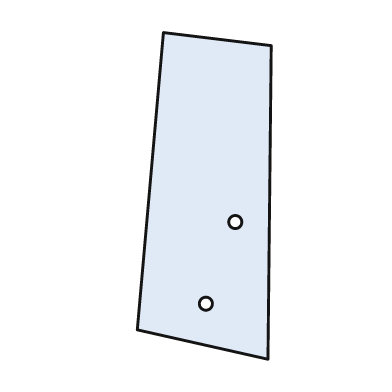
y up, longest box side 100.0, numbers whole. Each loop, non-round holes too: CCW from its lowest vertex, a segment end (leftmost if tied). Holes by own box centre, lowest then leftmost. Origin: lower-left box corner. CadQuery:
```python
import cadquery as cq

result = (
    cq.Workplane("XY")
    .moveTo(40.0, 0.0)
    .lineTo(41.0, 96.0)
    .lineTo(8.0, 100.0)
    .lineTo(0.0, 9.0)
    .close()
    .moveTo(21.0, 17.0)
    .circle(2.0)
    .moveTo(30.0, 42.0)
    .circle(2.0)
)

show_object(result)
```